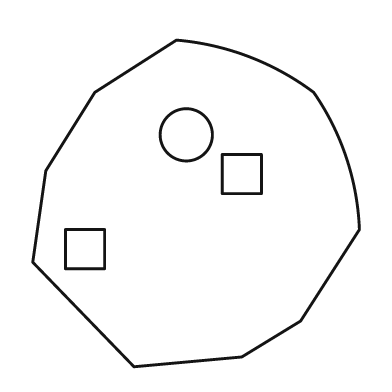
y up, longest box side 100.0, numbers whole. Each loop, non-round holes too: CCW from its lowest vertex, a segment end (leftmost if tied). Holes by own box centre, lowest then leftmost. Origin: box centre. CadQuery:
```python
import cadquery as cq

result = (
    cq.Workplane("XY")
    .moveTo(-19.0, -50.0)
    .lineTo(14.0, -47.0)
    .lineTo(32.0, -36.0)
    .lineTo(50.0, -8.0)
    .threePointArc((46.0, 14.0), (36.0, 34.0))
    .threePointArc((16.0, 45.0), (-6.0, 50.0))
    .lineTo(-31.0, 34.0)
    .lineTo(-46.0, 10.0)
    .lineTo(-50.0, -18.0)
    .close()
    .moveTo(-40.0, -20.0)
    .lineTo(-28.0, -20.0)
    .lineTo(-28.0, -8.0)
    .lineTo(-40.0, -8.0)
    .close()
    .moveTo(8.0, 3.0)
    .lineTo(20.0, 3.0)
    .lineTo(20.0, 15.0)
    .lineTo(8.0, 15.0)
    .close()
    .moveTo(-3.0, 21.0)
    .circle(8.0)
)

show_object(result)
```